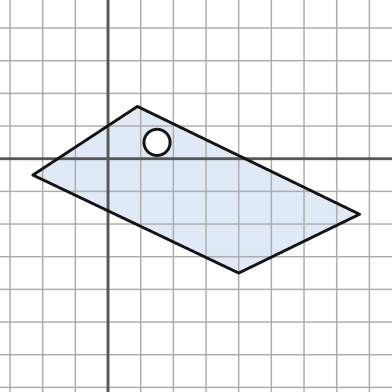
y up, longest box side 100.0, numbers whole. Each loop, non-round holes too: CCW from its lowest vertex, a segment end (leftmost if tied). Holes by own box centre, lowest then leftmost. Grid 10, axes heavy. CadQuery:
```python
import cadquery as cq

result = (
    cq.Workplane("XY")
    .moveTo(40.0, -35.0)
    .lineTo(77.0, -17.0)
    .lineTo(9.0, 16.0)
    .lineTo(-23.0, -5.0)
    .close()
    .moveTo(15.0, 5.0)
    .circle(4.0)
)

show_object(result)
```